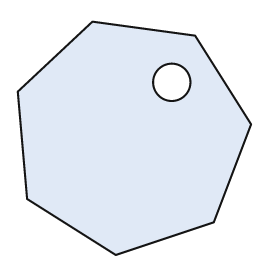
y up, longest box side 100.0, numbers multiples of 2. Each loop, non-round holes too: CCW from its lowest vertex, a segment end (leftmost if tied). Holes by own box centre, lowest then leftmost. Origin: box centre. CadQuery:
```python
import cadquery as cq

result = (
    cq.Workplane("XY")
    .moveTo(-8.0, -50.0)
    .lineTo(34.0, -36.0)
    .lineTo(50.0, 6.0)
    .lineTo(26.0, 44.0)
    .lineTo(-18.0, 50.0)
    .lineTo(-50.0, 20.0)
    .lineTo(-46.0, -26.0)
    .close()
    .moveTo(16.0, 24.0)
    .circle(8.0)
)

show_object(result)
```